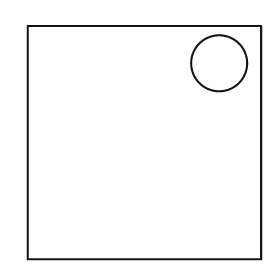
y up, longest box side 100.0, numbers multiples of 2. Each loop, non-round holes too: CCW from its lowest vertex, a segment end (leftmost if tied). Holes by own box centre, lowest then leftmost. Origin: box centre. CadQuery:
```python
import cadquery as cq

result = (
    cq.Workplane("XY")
    .moveTo(-50.0, -50.0)
    .lineTo(50.0, -50.0)
    .lineTo(50.0, 50.0)
    .lineTo(-50.0, 50.0)
    .close()
    .moveTo(32.0, 34.0)
    .circle(12.0)
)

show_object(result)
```